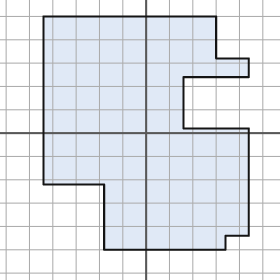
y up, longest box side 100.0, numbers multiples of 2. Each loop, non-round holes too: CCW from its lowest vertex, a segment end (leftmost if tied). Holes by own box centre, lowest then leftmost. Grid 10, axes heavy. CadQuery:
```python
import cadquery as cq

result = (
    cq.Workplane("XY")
    .moveTo(-18.0, -50.0)
    .lineTo(34.0, -50.0)
    .lineTo(34.0, -44.0)
    .lineTo(44.0, -44.0)
    .lineTo(44.0, 2.0)
    .lineTo(16.0, 2.0)
    .lineTo(16.0, 24.0)
    .lineTo(44.0, 24.0)
    .lineTo(44.0, 32.0)
    .lineTo(30.0, 32.0)
    .lineTo(30.0, 50.0)
    .lineTo(-44.0, 50.0)
    .lineTo(-44.0, -22.0)
    .lineTo(-18.0, -22.0)
    .close()
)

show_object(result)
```